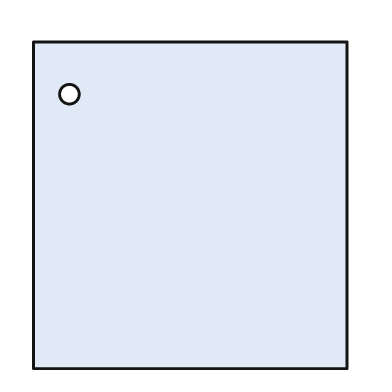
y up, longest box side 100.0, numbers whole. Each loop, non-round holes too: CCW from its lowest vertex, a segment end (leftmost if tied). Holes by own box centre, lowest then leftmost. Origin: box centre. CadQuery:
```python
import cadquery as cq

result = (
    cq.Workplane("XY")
    .moveTo(-48.0, -50.0)
    .lineTo(48.0, -50.0)
    .lineTo(48.0, 50.0)
    .lineTo(-48.0, 50.0)
    .close()
    .moveTo(-37.0, 34.0)
    .circle(3.0)
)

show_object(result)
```